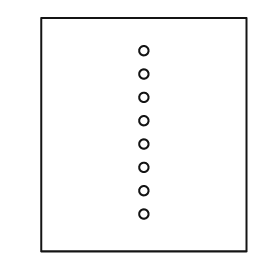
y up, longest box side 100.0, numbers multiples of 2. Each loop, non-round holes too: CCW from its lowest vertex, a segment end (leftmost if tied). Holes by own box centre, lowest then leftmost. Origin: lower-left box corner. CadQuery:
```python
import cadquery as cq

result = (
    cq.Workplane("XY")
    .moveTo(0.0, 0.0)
    .lineTo(88.0, 0.0)
    .lineTo(88.0, 100.0)
    .lineTo(0.0, 100.0)
    .close()
    .moveTo(44.0, 16.0)
    .circle(2.0)
    .moveTo(44.0, 26.0)
    .circle(2.0)
    .moveTo(44.0, 36.0)
    .circle(2.0)
    .moveTo(44.0, 46.0)
    .circle(2.0)
    .moveTo(44.0, 56.0)
    .circle(2.0)
    .moveTo(44.0, 66.0)
    .circle(2.0)
    .moveTo(44.0, 76.0)
    .circle(2.0)
    .moveTo(44.0, 86.0)
    .circle(2.0)
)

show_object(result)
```